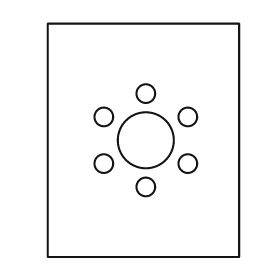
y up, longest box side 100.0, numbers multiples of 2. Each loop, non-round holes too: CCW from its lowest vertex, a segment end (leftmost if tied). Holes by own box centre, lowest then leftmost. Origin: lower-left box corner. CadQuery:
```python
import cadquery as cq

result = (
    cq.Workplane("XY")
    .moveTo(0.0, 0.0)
    .lineTo(82.0, 0.0)
    .lineTo(82.0, 100.0)
    .lineTo(0.0, 100.0)
    .close()
    .moveTo(42.0, 30.0)
    .circle(4.0)
    .moveTo(24.0, 40.0)
    .circle(4.0)
    .moveTo(60.0, 40.0)
    .circle(4.0)
    .moveTo(42.0, 50.0)
    .circle(12.0)
    .moveTo(24.0, 60.0)
    .circle(4.0)
    .moveTo(60.0, 60.0)
    .circle(4.0)
    .moveTo(42.0, 70.0)
    .circle(4.0)
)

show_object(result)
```